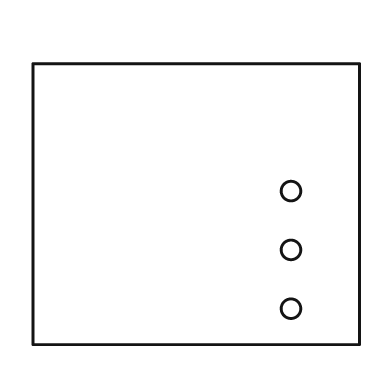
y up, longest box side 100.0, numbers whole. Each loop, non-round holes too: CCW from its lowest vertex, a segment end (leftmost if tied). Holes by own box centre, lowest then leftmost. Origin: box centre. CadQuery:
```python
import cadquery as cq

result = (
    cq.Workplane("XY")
    .moveTo(-50.0, -43.0)
    .lineTo(50.0, -43.0)
    .lineTo(50.0, 43.0)
    .lineTo(-50.0, 43.0)
    .close()
    .moveTo(29.0, -32.0)
    .circle(3.0)
    .moveTo(29.0, -14.0)
    .circle(3.0)
    .moveTo(29.0, 4.0)
    .circle(3.0)
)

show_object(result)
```